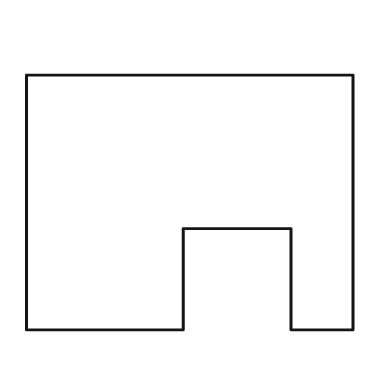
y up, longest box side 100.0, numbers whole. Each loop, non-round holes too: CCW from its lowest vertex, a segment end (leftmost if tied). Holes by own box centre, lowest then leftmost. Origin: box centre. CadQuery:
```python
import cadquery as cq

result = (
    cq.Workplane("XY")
    .moveTo(-50.0, -39.0)
    .lineTo(-2.0, -39.0)
    .lineTo(-2.0, -8.0)
    .lineTo(31.0, -8.0)
    .lineTo(31.0, -39.0)
    .lineTo(50.0, -39.0)
    .lineTo(50.0, 39.0)
    .lineTo(-50.0, 39.0)
    .close()
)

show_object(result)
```